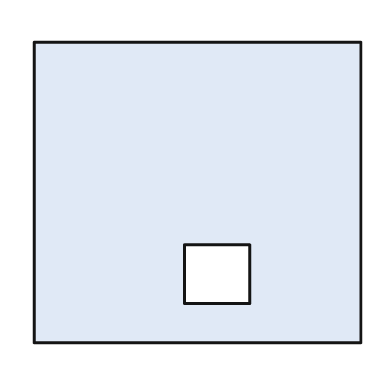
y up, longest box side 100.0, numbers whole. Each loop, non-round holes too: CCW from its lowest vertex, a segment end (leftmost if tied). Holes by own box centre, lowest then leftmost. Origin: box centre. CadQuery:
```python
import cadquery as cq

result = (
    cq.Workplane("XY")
    .moveTo(-50.0, -46.0)
    .lineTo(50.0, -46.0)
    .lineTo(50.0, 46.0)
    .lineTo(-50.0, 46.0)
    .close()
    .moveTo(-4.0, -34.0)
    .lineTo(16.0, -34.0)
    .lineTo(16.0, -16.0)
    .lineTo(-4.0, -16.0)
    .close()
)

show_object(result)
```